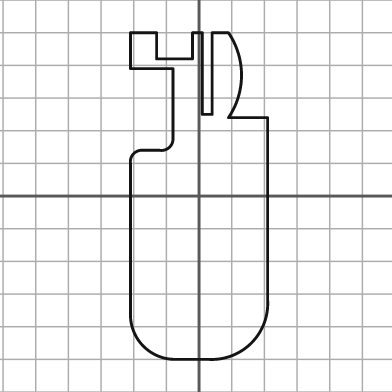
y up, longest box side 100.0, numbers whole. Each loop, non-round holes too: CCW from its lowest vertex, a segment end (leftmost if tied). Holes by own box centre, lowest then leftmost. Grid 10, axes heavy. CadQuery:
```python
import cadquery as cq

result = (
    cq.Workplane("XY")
    .moveTo(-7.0, -50.0)
    .lineTo(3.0, -50.0)
    .threePointArc((16.0, -45.0), (21.0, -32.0))
    .lineTo(21.0, 24.0)
    .lineTo(9.0, 24.0)
    .threePointArc((13.0, 37.0), (9.0, 50.0))
    .lineTo(4.0, 50.0)
    .lineTo(4.0, 25.0)
    .lineTo(1.0, 25.0)
    .lineTo(1.0, 50.0)
    .lineTo(-2.0, 50.0)
    .lineTo(-2.0, 42.0)
    .lineTo(-13.0, 42.0)
    .lineTo(-13.0, 50.0)
    .lineTo(-21.0, 50.0)
    .lineTo(-21.0, 39.0)
    .lineTo(-8.0, 39.0)
    .lineTo(-8.0, 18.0)
    .threePointArc((-9.0, 15.0), (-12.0, 14.0))
    .lineTo(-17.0, 14.0)
    .threePointArc((-20.0, 13.0), (-21.0, 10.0))
    .lineTo(-21.0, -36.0)
    .threePointArc((-17.0, -46.0), (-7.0, -50.0))
    .close()
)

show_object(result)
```